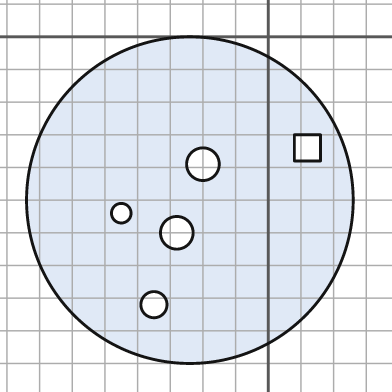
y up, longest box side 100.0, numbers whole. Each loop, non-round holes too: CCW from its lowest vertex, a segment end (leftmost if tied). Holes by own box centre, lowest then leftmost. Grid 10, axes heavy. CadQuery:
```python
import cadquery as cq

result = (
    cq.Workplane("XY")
    .moveTo(-24.0, -50.0)
    .circle(50.0)
    .moveTo(-35.0, -82.0)
    .circle(4.0)
    .moveTo(-28.0, -60.0)
    .circle(5.0)
    .moveTo(-45.0, -54.0)
    .circle(3.0)
    .moveTo(-20.0, -39.0)
    .circle(5.0)
    .moveTo(8.0, -38.0)
    .lineTo(16.0, -38.0)
    .lineTo(16.0, -30.0)
    .lineTo(8.0, -30.0)
    .close()
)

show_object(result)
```